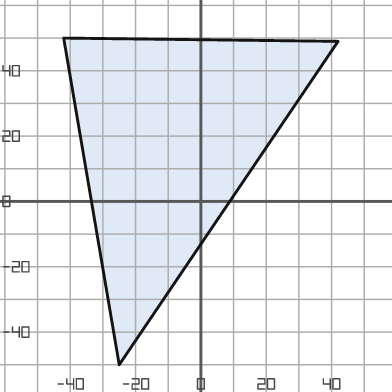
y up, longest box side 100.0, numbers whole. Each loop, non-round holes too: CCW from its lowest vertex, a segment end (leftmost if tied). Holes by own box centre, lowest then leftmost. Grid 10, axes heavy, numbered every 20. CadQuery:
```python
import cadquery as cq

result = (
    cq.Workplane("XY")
    .moveTo(-25.0, -50.0)
    .lineTo(42.0, 49.0)
    .lineTo(-42.0, 50.0)
    .close()
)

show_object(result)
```